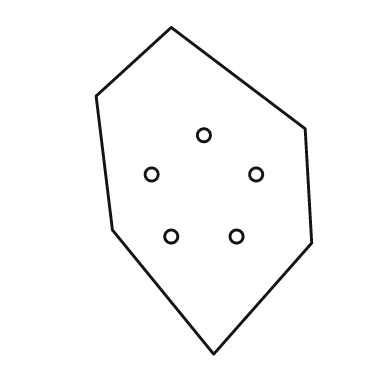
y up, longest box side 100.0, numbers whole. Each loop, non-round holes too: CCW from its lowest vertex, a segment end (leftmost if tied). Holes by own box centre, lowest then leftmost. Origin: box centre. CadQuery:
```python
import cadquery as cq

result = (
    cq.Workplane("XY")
    .moveTo(3.0, -50.0)
    .lineTo(33.0, -16.0)
    .lineTo(31.0, 19.0)
    .lineTo(-10.0, 50.0)
    .lineTo(-33.0, 29.0)
    .lineTo(-28.0, -12.0)
    .close()
    .moveTo(-10.0, -14.0)
    .circle(2.0)
    .moveTo(10.0, -14.0)
    .circle(2.0)
    .moveTo(-16.0, 5.0)
    .circle(2.0)
    .moveTo(16.0, 5.0)
    .circle(2.0)
    .moveTo(0.0, 17.0)
    .circle(2.0)
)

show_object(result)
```